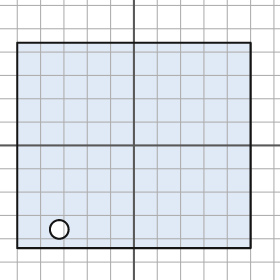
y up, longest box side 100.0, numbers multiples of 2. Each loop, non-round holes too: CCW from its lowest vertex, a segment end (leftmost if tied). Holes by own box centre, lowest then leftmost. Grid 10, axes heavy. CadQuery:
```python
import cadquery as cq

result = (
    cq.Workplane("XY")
    .moveTo(-50.0, -44.0)
    .lineTo(50.0, -44.0)
    .lineTo(50.0, 44.0)
    .lineTo(-50.0, 44.0)
    .close()
    .moveTo(-32.0, -36.0)
    .circle(4.0)
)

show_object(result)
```